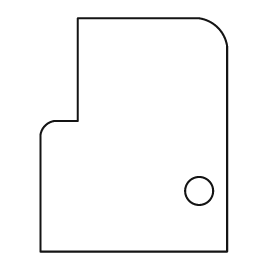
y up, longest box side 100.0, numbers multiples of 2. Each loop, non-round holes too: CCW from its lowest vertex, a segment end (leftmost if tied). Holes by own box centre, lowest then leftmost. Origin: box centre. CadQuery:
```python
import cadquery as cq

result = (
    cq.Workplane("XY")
    .moveTo(-40.0, -50.0)
    .lineTo(40.0, -50.0)
    .lineTo(40.0, 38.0)
    .threePointArc((36.0, 46.0), (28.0, 50.0))
    .lineTo(-24.0, 50.0)
    .lineTo(-24.0, 6.0)
    .lineTo(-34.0, 6.0)
    .threePointArc((-38.0, 4.0), (-40.0, 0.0))
    .close()
    .moveTo(28.0, -24.0)
    .circle(6.0)
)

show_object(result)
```